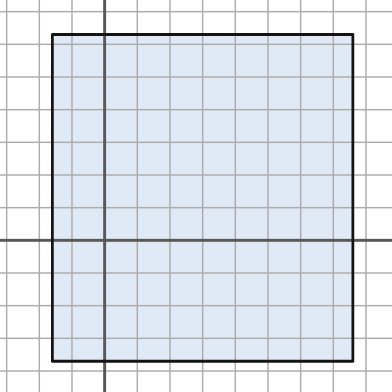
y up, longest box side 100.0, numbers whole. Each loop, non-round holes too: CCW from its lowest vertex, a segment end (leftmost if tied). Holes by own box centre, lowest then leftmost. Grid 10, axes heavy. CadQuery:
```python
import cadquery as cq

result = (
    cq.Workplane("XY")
    .moveTo(-16.0, -37.0)
    .lineTo(76.0, -37.0)
    .lineTo(76.0, 63.0)
    .lineTo(-16.0, 63.0)
    .close()
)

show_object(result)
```